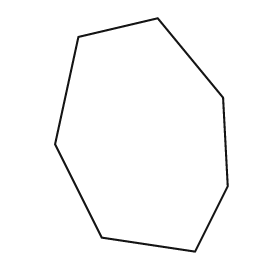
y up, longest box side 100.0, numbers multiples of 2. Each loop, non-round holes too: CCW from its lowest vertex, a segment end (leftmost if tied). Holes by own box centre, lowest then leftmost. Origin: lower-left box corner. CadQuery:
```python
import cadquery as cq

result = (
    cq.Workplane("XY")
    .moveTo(60.0, 0.0)
    .lineTo(74.0, 28.0)
    .lineTo(72.0, 66.0)
    .lineTo(44.0, 100.0)
    .lineTo(10.0, 92.0)
    .lineTo(0.0, 46.0)
    .lineTo(20.0, 6.0)
    .close()
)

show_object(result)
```